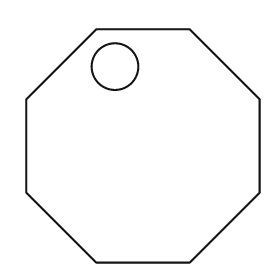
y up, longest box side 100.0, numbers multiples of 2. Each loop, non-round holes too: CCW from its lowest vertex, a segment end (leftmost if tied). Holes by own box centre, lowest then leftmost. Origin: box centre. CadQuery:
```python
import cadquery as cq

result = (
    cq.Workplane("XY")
    .moveTo(-20.0, -50.0)
    .lineTo(20.0, -50.0)
    .lineTo(50.0, -20.0)
    .lineTo(50.0, 20.0)
    .lineTo(20.0, 50.0)
    .lineTo(-20.0, 50.0)
    .lineTo(-50.0, 20.0)
    .lineTo(-50.0, -20.0)
    .close()
    .moveTo(-12.0, 34.0)
    .circle(10.0)
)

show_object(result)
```